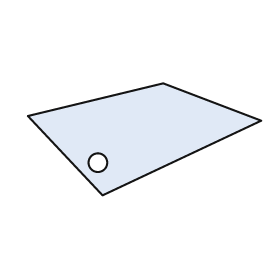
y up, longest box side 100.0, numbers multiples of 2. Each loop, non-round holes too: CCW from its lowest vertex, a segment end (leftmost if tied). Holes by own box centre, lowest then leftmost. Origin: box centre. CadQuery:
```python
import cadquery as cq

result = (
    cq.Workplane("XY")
    .moveTo(-18.0, -24.0)
    .lineTo(50.0, 8.0)
    .lineTo(8.0, 24.0)
    .lineTo(-50.0, 10.0)
    .close()
    .moveTo(-20.0, -10.0)
    .circle(4.0)
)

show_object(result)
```